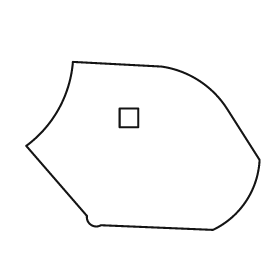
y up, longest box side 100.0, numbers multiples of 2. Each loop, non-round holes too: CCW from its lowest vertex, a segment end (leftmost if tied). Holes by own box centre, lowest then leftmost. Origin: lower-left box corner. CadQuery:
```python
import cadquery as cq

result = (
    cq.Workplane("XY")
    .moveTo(80.0, 0.0)
    .threePointArc((94.0, 12.0), (100.0, 30.0))
    .lineTo(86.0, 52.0)
    .threePointArc((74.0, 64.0), (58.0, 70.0))
    .lineTo(20.0, 72.0)
    .threePointArc((14.0, 52.0), (0.0, 36.0))
    .lineTo(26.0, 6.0)
    .threePointArc((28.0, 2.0), (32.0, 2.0))
    .close()
    .moveTo(40.0, 44.0)
    .lineTo(48.0, 44.0)
    .lineTo(48.0, 52.0)
    .lineTo(40.0, 52.0)
    .close()
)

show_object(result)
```